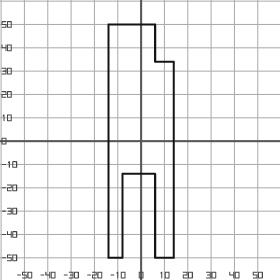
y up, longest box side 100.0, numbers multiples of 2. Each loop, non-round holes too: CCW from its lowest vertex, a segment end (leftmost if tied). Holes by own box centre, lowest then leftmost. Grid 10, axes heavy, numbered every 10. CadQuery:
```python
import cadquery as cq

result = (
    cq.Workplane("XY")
    .moveTo(-14.0, -50.0)
    .lineTo(-8.0, -50.0)
    .lineTo(-8.0, -14.0)
    .lineTo(6.0, -14.0)
    .lineTo(6.0, -50.0)
    .lineTo(14.0, -50.0)
    .lineTo(14.0, 34.0)
    .lineTo(6.0, 34.0)
    .lineTo(6.0, 50.0)
    .lineTo(-14.0, 50.0)
    .close()
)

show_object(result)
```